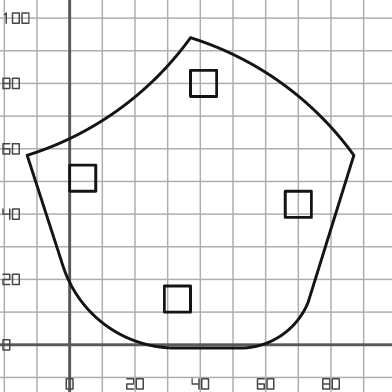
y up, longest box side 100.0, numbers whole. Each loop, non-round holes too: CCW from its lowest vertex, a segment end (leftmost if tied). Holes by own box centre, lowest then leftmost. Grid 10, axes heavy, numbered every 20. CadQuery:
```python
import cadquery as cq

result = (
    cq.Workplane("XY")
    .moveTo(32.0, -1.0)
    .lineTo(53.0, -1.0)
    .threePointArc((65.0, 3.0), (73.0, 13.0))
    .lineTo(87.0, 58.0)
    .threePointArc((65.0, 80.0), (37.0, 94.0))
    .threePointArc((15.0, 72.0), (-13.0, 58.0))
    .lineTo(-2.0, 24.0)
    .threePointArc((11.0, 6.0), (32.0, -1.0))
    .close()
    .moveTo(29.0, 10.0)
    .lineTo(37.0, 10.0)
    .lineTo(37.0, 18.0)
    .lineTo(29.0, 18.0)
    .close()
    .moveTo(66.0, 39.0)
    .lineTo(74.0, 39.0)
    .lineTo(74.0, 47.0)
    .lineTo(66.0, 47.0)
    .close()
    .moveTo(0.0, 47.0)
    .lineTo(8.0, 47.0)
    .lineTo(8.0, 55.0)
    .lineTo(0.0, 55.0)
    .close()
    .moveTo(37.0, 76.0)
    .lineTo(45.0, 76.0)
    .lineTo(45.0, 84.0)
    .lineTo(37.0, 84.0)
    .close()
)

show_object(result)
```